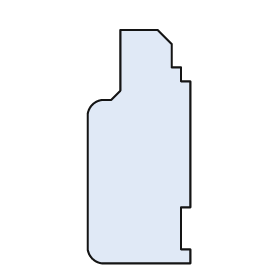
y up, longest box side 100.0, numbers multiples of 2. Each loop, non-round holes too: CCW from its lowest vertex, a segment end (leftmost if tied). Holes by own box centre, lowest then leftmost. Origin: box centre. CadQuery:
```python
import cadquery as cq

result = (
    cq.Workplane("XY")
    .moveTo(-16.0, -50.0)
    .lineTo(22.0, -50.0)
    .lineTo(22.0, -44.0)
    .lineTo(18.0, -44.0)
    .lineTo(18.0, -26.0)
    .lineTo(22.0, -26.0)
    .lineTo(22.0, 28.0)
    .lineTo(18.0, 28.0)
    .lineTo(18.0, 34.0)
    .lineTo(14.0, 34.0)
    .lineTo(14.0, 44.0)
    .lineTo(8.0, 50.0)
    .lineTo(-8.0, 50.0)
    .lineTo(-8.0, 24.0)
    .lineTo(-12.0, 20.0)
    .lineTo(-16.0, 20.0)
    .threePointArc((-20.0, 18.0), (-22.0, 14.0))
    .lineTo(-22.0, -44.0)
    .threePointArc((-20.0, -48.0), (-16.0, -50.0))
    .close()
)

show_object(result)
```